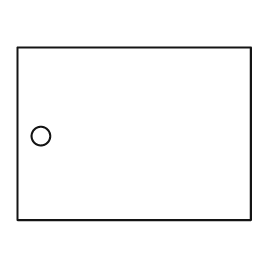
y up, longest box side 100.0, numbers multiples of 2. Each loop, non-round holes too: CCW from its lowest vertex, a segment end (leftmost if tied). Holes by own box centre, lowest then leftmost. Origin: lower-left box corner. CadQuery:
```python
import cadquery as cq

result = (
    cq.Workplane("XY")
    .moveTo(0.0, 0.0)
    .lineTo(100.0, 0.0)
    .lineTo(100.0, 74.0)
    .lineTo(0.0, 74.0)
    .close()
    .moveTo(10.0, 36.0)
    .circle(4.0)
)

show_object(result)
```